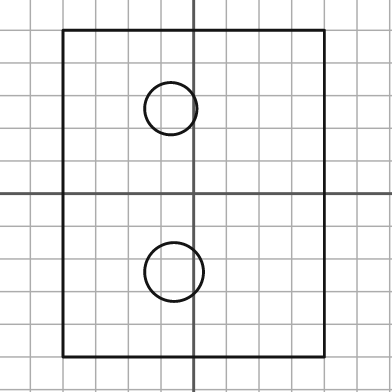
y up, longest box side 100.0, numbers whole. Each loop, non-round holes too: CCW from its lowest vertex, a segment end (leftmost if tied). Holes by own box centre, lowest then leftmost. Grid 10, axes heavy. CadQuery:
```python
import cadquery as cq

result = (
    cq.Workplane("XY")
    .moveTo(-40.0, -50.0)
    .lineTo(40.0, -50.0)
    .lineTo(40.0, 50.0)
    .lineTo(-40.0, 50.0)
    .close()
    .moveTo(-6.0, -24.0)
    .circle(9.0)
    .moveTo(-7.0, 26.0)
    .circle(8.0)
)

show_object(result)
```